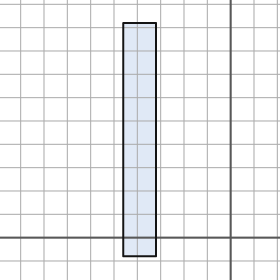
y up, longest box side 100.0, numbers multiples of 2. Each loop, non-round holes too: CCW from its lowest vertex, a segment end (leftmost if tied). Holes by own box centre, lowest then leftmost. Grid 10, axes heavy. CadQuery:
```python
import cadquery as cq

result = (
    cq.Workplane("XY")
    .moveTo(-46.0, -8.0)
    .lineTo(-32.0, -8.0)
    .lineTo(-32.0, 92.0)
    .lineTo(-46.0, 92.0)
    .close()
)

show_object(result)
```